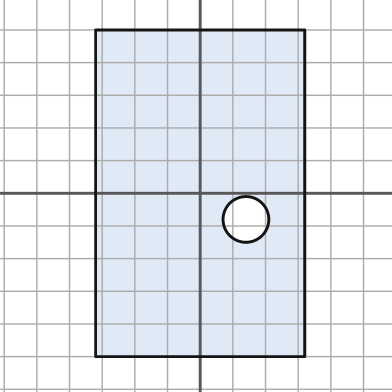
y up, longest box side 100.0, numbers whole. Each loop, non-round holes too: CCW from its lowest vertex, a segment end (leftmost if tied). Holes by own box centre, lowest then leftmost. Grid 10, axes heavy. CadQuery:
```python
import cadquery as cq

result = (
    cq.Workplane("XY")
    .moveTo(-32.0, -50.0)
    .lineTo(32.0, -50.0)
    .lineTo(32.0, 50.0)
    .lineTo(-32.0, 50.0)
    .close()
    .moveTo(14.0, -8.0)
    .circle(7.0)
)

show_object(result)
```